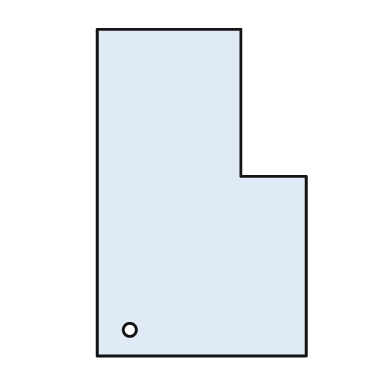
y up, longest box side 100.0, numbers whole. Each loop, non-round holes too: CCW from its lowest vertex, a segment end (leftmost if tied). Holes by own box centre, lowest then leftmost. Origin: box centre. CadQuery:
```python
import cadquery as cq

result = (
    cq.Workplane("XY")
    .moveTo(-32.0, -50.0)
    .lineTo(32.0, -50.0)
    .lineTo(32.0, 5.0)
    .lineTo(12.0, 5.0)
    .lineTo(12.0, 50.0)
    .lineTo(-32.0, 50.0)
    .close()
    .moveTo(-22.0, -42.0)
    .circle(2.0)
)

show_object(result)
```